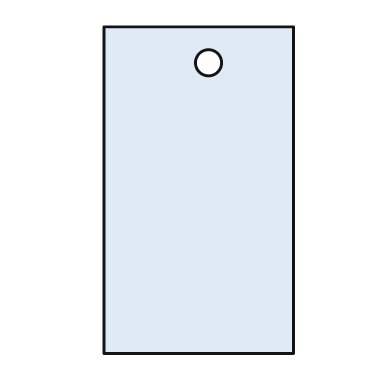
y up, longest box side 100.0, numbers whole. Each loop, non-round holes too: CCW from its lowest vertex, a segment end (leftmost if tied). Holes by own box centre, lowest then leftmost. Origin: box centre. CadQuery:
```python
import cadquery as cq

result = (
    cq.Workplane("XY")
    .moveTo(-29.0, -50.0)
    .lineTo(29.0, -50.0)
    .lineTo(29.0, 50.0)
    .lineTo(-29.0, 50.0)
    .close()
    .moveTo(3.0, 39.0)
    .circle(4.0)
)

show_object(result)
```